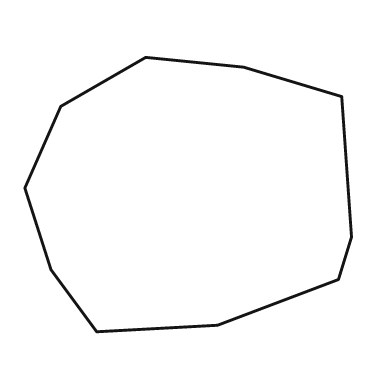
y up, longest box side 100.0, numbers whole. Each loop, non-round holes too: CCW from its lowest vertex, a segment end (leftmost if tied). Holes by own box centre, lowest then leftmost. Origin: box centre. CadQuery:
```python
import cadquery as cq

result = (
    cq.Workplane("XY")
    .moveTo(-28.0, -42.0)
    .lineTo(9.0, -40.0)
    .lineTo(46.0, -26.0)
    .lineTo(50.0, -13.0)
    .lineTo(47.0, 30.0)
    .lineTo(17.0, 39.0)
    .lineTo(-13.0, 42.0)
    .lineTo(-39.0, 27.0)
    .lineTo(-50.0, 2.0)
    .lineTo(-42.0, -23.0)
    .close()
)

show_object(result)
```